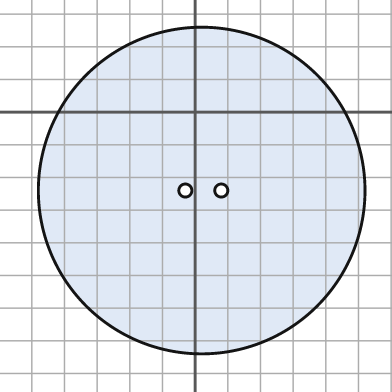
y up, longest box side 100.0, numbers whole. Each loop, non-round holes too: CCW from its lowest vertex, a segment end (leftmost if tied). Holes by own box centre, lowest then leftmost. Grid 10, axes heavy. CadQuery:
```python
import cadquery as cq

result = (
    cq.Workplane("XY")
    .moveTo(2.0, -24.0)
    .circle(50.0)
    .moveTo(-3.0, -24.0)
    .circle(2.0)
    .moveTo(8.0, -24.0)
    .circle(2.0)
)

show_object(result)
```